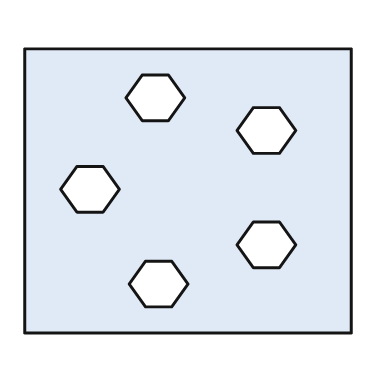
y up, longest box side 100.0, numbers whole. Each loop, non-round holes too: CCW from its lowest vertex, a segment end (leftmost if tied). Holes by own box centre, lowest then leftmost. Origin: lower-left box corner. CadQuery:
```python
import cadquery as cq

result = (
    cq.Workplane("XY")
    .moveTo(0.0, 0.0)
    .lineTo(100.0, 0.0)
    .lineTo(100.0, 87.0)
    .lineTo(0.0, 87.0)
    .close()
    .moveTo(37.0, 8.0)
    .lineTo(45.0, 8.0)
    .lineTo(50.0, 15.0)
    .lineTo(45.0, 22.0)
    .lineTo(37.0, 22.0)
    .lineTo(32.0, 15.0)
    .close()
    .moveTo(70.0, 20.0)
    .lineTo(78.0, 20.0)
    .lineTo(83.0, 27.0)
    .lineTo(78.0, 34.0)
    .lineTo(70.0, 34.0)
    .lineTo(65.0, 27.0)
    .close()
    .moveTo(16.0, 37.0)
    .lineTo(24.0, 37.0)
    .lineTo(29.0, 44.0)
    .lineTo(24.0, 51.0)
    .lineTo(16.0, 51.0)
    .lineTo(11.0, 44.0)
    .close()
    .moveTo(70.0, 55.0)
    .lineTo(78.0, 55.0)
    .lineTo(83.0, 62.0)
    .lineTo(78.0, 69.0)
    .lineTo(70.0, 69.0)
    .lineTo(65.0, 62.0)
    .close()
    .moveTo(36.0, 65.0)
    .lineTo(44.0, 65.0)
    .lineTo(49.0, 72.0)
    .lineTo(44.0, 79.0)
    .lineTo(36.0, 79.0)
    .lineTo(31.0, 72.0)
    .close()
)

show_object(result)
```